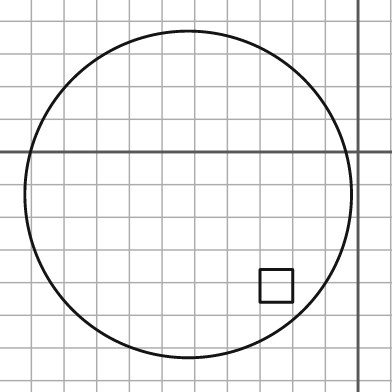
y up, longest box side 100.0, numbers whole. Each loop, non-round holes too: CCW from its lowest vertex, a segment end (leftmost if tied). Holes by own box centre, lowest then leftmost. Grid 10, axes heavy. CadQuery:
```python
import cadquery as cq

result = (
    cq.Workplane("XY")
    .moveTo(-52.0, -13.0)
    .circle(50.0)
    .moveTo(-30.0, -46.0)
    .lineTo(-20.0, -46.0)
    .lineTo(-20.0, -36.0)
    .lineTo(-30.0, -36.0)
    .close()
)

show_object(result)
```